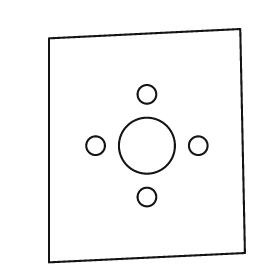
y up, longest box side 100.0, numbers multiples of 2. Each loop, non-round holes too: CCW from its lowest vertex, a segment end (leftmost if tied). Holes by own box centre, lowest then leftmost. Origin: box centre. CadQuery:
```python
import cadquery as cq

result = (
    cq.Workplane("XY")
    .moveTo(-42.0, -50.0)
    .lineTo(42.0, -46.0)
    .lineTo(40.0, 50.0)
    .lineTo(-42.0, 46.0)
    .close()
    .moveTo(0.0, -22.0)
    .circle(4.0)
    .moveTo(-22.0, 0.0)
    .circle(4.0)
    .moveTo(0.0, 0.0)
    .circle(12.0)
    .moveTo(22.0, 0.0)
    .circle(4.0)
    .moveTo(0.0, 22.0)
    .circle(4.0)
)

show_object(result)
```